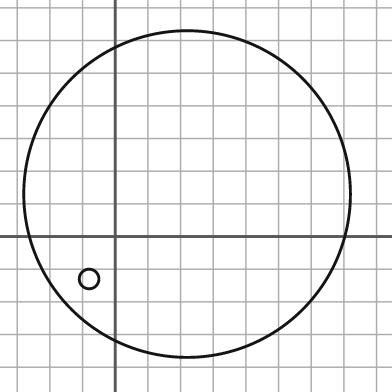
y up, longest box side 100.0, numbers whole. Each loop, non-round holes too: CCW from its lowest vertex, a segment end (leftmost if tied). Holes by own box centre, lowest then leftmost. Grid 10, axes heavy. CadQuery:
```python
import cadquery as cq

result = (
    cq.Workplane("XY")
    .moveTo(22.0, 13.0)
    .circle(50.0)
    .moveTo(-8.0, -13.0)
    .circle(3.0)
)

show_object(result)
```